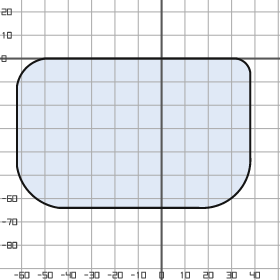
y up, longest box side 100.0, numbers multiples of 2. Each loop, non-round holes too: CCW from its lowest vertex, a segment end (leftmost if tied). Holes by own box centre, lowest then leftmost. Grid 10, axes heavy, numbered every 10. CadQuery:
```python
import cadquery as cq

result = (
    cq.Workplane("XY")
    .moveTo(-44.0, -64.0)
    .lineTo(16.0, -64.0)
    .threePointArc((32.0, -58.0), (38.0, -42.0))
    .lineTo(38.0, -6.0)
    .threePointArc((36.0, -2.0), (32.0, 0.0))
    .lineTo(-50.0, 0.0)
    .threePointArc((-58.0, -4.0), (-62.0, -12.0))
    .lineTo(-62.0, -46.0)
    .threePointArc((-56.0, -58.0), (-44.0, -64.0))
    .close()
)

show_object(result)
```